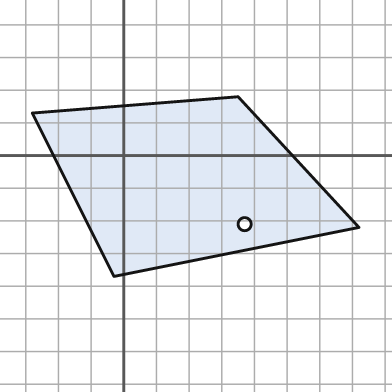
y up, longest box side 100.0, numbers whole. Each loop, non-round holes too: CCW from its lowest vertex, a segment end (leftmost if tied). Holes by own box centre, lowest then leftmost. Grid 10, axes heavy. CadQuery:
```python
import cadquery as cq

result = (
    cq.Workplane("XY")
    .moveTo(-3.0, -37.0)
    .lineTo(72.0, -22.0)
    .lineTo(35.0, 18.0)
    .lineTo(-28.0, 13.0)
    .close()
    .moveTo(37.0, -21.0)
    .circle(2.0)
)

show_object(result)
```